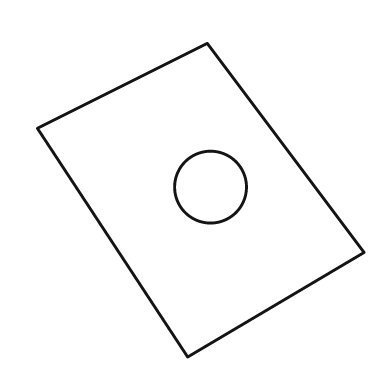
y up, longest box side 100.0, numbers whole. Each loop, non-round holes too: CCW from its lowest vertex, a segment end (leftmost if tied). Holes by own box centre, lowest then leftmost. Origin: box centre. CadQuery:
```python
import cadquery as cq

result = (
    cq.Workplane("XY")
    .moveTo(-4.0, -48.0)
    .lineTo(50.0, -16.0)
    .lineTo(2.0, 48.0)
    .lineTo(-50.0, 22.0)
    .close()
    .moveTo(3.0, 4.0)
    .circle(11.0)
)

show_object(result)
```